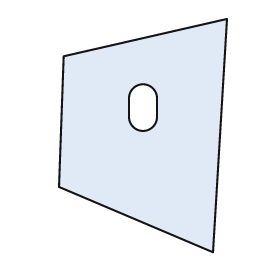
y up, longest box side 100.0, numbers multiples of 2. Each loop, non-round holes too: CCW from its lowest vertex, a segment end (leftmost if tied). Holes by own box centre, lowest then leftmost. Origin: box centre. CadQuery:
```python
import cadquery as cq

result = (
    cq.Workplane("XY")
    .moveTo(30.0, -50.0)
    .lineTo(36.0, 50.0)
    .lineTo(-34.0, 34.0)
    .lineTo(-36.0, -22.0)
    .close()
    .moveTo(-6.0, 8.0)
    .threePointArc((0.0, 2.0), (6.0, 8.0))
    .lineTo(6.0, 16.0)
    .threePointArc((0.0, 22.0), (-6.0, 16.0))
    .close()
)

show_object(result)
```